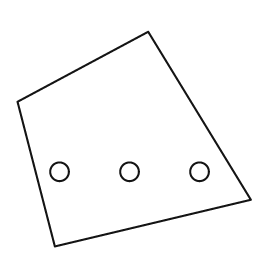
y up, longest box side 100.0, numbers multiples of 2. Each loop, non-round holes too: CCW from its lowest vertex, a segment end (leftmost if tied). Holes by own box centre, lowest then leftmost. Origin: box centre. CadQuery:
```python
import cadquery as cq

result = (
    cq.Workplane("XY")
    .moveTo(-34.0, -46.0)
    .lineTo(50.0, -26.0)
    .lineTo(6.0, 46.0)
    .lineTo(-50.0, 16.0)
    .close()
    .moveTo(-32.0, -14.0)
    .circle(4.0)
    .moveTo(-2.0, -14.0)
    .circle(4.0)
    .moveTo(28.0, -14.0)
    .circle(4.0)
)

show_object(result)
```